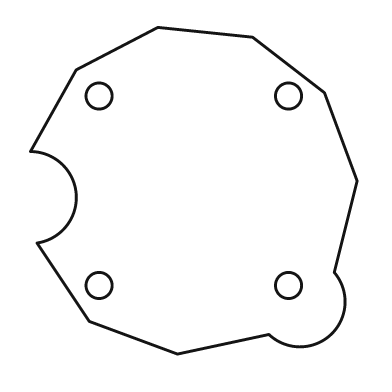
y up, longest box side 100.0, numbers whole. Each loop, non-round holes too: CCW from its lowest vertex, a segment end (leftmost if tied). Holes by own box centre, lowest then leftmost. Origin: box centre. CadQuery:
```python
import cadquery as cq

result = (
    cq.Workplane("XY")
    .moveTo(-5.0, -50.0)
    .lineTo(23.0, -44.0)
    .threePointArc((42.0, -44.0), (43.0, -25.0))
    .lineTo(50.0, 3.0)
    .lineTo(40.0, 30.0)
    .lineTo(18.0, 47.0)
    .lineTo(-11.0, 50.0)
    .lineTo(-36.0, 37.0)
    .lineTo(-50.0, 12.0)
    .threePointArc((-36.0, -1.0), (-48.0, -16.0))
    .lineTo(-32.0, -40.0)
    .close()
    .moveTo(-29.0, -29.0)
    .circle(4.0)
    .moveTo(29.0, -29.0)
    .circle(4.0)
    .moveTo(-29.0, 29.0)
    .circle(4.0)
    .moveTo(29.0, 29.0)
    .circle(4.0)
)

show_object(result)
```